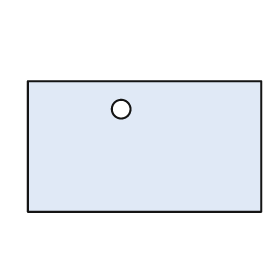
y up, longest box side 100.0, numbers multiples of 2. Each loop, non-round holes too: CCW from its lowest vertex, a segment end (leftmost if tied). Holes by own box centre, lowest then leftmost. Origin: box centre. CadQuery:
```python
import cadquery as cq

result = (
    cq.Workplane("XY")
    .moveTo(-50.0, -28.0)
    .lineTo(50.0, -28.0)
    .lineTo(50.0, 28.0)
    .lineTo(-50.0, 28.0)
    .close()
    .moveTo(-10.0, 16.0)
    .circle(4.0)
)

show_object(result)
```